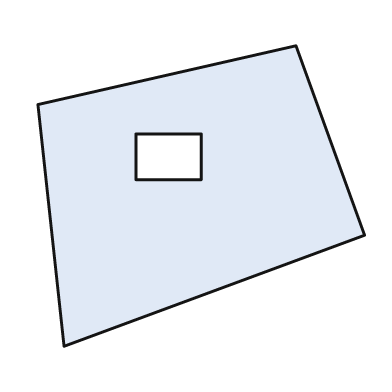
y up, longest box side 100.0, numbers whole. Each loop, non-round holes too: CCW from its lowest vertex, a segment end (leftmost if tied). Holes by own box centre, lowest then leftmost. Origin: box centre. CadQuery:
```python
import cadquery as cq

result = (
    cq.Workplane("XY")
    .moveTo(-42.0, -46.0)
    .lineTo(50.0, -12.0)
    .lineTo(29.0, 46.0)
    .lineTo(-50.0, 28.0)
    .close()
    .moveTo(-20.0, 5.0)
    .lineTo(0.0, 5.0)
    .lineTo(0.0, 19.0)
    .lineTo(-20.0, 19.0)
    .close()
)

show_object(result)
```